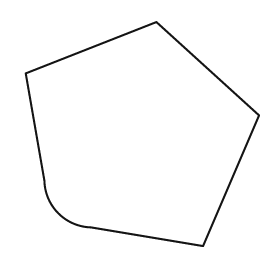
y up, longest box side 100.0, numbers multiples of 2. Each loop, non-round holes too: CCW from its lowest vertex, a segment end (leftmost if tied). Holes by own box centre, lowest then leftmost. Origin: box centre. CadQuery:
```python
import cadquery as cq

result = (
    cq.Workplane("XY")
    .moveTo(26.0, -48.0)
    .lineTo(50.0, 8.0)
    .lineTo(6.0, 48.0)
    .lineTo(-50.0, 26.0)
    .lineTo(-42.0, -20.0)
    .threePointArc((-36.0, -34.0), (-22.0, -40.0))
    .close()
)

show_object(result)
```